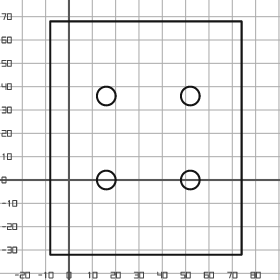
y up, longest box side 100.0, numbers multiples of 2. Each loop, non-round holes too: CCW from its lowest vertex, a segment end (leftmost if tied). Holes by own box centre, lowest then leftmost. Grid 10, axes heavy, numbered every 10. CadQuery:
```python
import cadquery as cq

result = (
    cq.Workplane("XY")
    .moveTo(-8.0, -32.0)
    .lineTo(74.0, -32.0)
    .lineTo(74.0, 68.0)
    .lineTo(-8.0, 68.0)
    .close()
    .moveTo(16.0, 0.0)
    .circle(4.0)
    .moveTo(52.0, 0.0)
    .circle(4.0)
    .moveTo(16.0, 36.0)
    .circle(4.0)
    .moveTo(52.0, 36.0)
    .circle(4.0)
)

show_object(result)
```